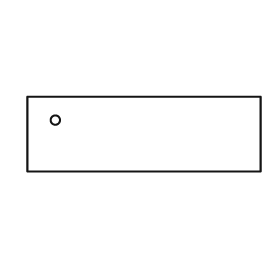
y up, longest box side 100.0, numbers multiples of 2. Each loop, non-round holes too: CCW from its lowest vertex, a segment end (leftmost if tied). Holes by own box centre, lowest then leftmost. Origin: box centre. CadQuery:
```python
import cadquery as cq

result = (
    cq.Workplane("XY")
    .moveTo(-50.0, -16.0)
    .lineTo(50.0, -16.0)
    .lineTo(50.0, 16.0)
    .lineTo(-50.0, 16.0)
    .close()
    .moveTo(-38.0, 6.0)
    .circle(2.0)
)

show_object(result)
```